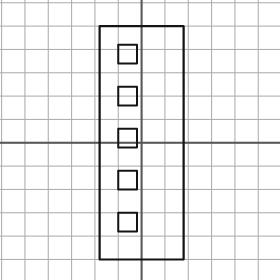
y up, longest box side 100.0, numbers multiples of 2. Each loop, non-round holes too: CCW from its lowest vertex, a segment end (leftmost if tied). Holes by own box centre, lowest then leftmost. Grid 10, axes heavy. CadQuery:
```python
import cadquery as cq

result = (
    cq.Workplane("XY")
    .moveTo(-18.0, -50.0)
    .lineTo(18.0, -50.0)
    .lineTo(18.0, 50.0)
    .lineTo(-18.0, 50.0)
    .close()
    .moveTo(-10.0, -38.0)
    .lineTo(-2.0, -38.0)
    .lineTo(-2.0, -30.0)
    .lineTo(-10.0, -30.0)
    .close()
    .moveTo(-10.0, -20.0)
    .lineTo(-2.0, -20.0)
    .lineTo(-2.0, -12.0)
    .lineTo(-10.0, -12.0)
    .close()
    .moveTo(-10.0, -2.0)
    .lineTo(-2.0, -2.0)
    .lineTo(-2.0, 6.0)
    .lineTo(-10.0, 6.0)
    .close()
    .moveTo(-10.0, 16.0)
    .lineTo(-2.0, 16.0)
    .lineTo(-2.0, 24.0)
    .lineTo(-10.0, 24.0)
    .close()
    .moveTo(-10.0, 34.0)
    .lineTo(-2.0, 34.0)
    .lineTo(-2.0, 42.0)
    .lineTo(-10.0, 42.0)
    .close()
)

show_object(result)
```